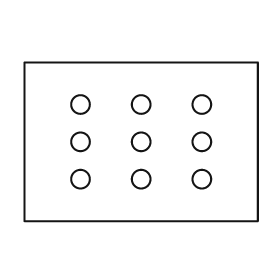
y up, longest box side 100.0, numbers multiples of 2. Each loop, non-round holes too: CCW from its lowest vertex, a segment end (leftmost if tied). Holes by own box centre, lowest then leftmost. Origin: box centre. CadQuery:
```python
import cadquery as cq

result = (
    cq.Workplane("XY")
    .moveTo(-50.0, -34.0)
    .lineTo(50.0, -34.0)
    .lineTo(50.0, 34.0)
    .lineTo(-50.0, 34.0)
    .close()
    .moveTo(-26.0, -16.0)
    .circle(4.0)
    .moveTo(0.0, -16.0)
    .circle(4.0)
    .moveTo(26.0, -16.0)
    .circle(4.0)
    .moveTo(-26.0, 0.0)
    .circle(4.0)
    .moveTo(0.0, 0.0)
    .circle(4.0)
    .moveTo(26.0, 0.0)
    .circle(4.0)
    .moveTo(-26.0, 16.0)
    .circle(4.0)
    .moveTo(0.0, 16.0)
    .circle(4.0)
    .moveTo(26.0, 16.0)
    .circle(4.0)
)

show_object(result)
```